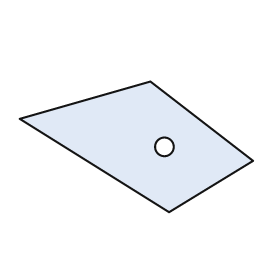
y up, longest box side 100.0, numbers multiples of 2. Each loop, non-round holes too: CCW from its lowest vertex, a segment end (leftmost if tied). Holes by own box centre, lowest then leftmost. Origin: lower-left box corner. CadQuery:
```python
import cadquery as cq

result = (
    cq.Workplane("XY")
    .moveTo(64.0, 0.0)
    .lineTo(100.0, 22.0)
    .lineTo(56.0, 56.0)
    .lineTo(0.0, 40.0)
    .close()
    .moveTo(62.0, 28.0)
    .circle(4.0)
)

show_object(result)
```